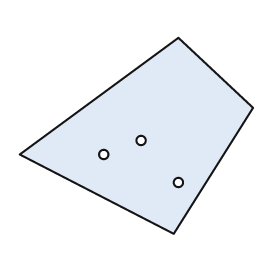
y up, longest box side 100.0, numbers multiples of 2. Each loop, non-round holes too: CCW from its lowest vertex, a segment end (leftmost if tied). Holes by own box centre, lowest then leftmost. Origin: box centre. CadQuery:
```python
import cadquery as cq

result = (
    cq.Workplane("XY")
    .moveTo(16.0, -42.0)
    .lineTo(50.0, 12.0)
    .lineTo(18.0, 42.0)
    .lineTo(-50.0, -8.0)
    .close()
    .moveTo(18.0, -20.0)
    .circle(2.0)
    .moveTo(-14.0, -8.0)
    .circle(2.0)
    .moveTo(2.0, -2.0)
    .circle(2.0)
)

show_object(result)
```